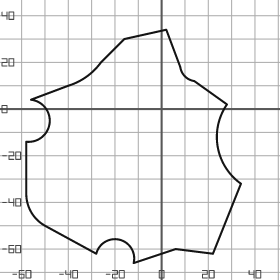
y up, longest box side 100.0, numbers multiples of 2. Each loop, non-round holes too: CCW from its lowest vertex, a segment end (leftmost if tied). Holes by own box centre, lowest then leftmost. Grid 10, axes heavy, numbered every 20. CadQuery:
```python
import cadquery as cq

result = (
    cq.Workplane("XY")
    .moveTo(-12.0, -66.0)
    .lineTo(6.0, -60.0)
    .lineTo(22.0, -62.0)
    .lineTo(34.0, -32.0)
    .threePointArc((24.0, -16.0), (28.0, 2.0))
    .lineTo(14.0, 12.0)
    .threePointArc((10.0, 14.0), (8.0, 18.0))
    .lineTo(2.0, 34.0)
    .lineTo(-16.0, 30.0)
    .lineTo(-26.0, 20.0)
    .threePointArc((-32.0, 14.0), (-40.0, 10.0))
    .lineTo(-56.0, 4.0)
    .threePointArc((-48.0, -6.0), (-58.0, -14.0))
    .lineTo(-58.0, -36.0)
    .threePointArc((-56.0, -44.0), (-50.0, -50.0))
    .lineTo(-28.0, -62.0)
    .threePointArc((-18.0, -56.0), (-12.0, -66.0))
    .close()
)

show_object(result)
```